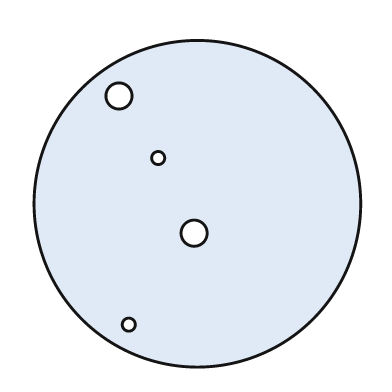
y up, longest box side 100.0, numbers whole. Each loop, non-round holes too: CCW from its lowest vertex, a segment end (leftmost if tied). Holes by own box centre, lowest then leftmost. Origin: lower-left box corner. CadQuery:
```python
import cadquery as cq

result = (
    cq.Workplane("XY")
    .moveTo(50.0, 50.0)
    .circle(50.0)
    .moveTo(29.0, 13.0)
    .circle(2.0)
    .moveTo(49.0, 41.0)
    .circle(4.0)
    .moveTo(38.0, 64.0)
    .circle(2.0)
    .moveTo(26.0, 83.0)
    .circle(4.0)
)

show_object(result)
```